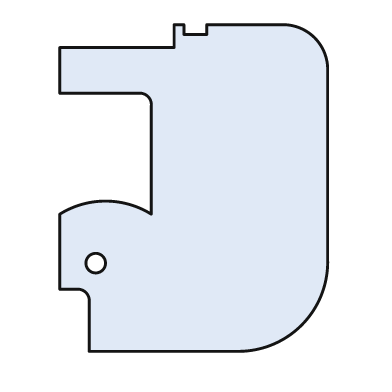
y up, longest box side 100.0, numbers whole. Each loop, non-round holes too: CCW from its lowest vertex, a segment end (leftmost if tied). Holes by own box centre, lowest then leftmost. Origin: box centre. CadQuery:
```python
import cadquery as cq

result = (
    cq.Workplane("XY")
    .moveTo(-32.0, -50.0)
    .lineTo(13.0, -50.0)
    .threePointArc((33.0, -42.0), (41.0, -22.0))
    .lineTo(41.0, 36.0)
    .threePointArc((37.0, 46.0), (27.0, 50.0))
    .lineTo(4.0, 50.0)
    .lineTo(4.0, 47.0)
    .lineTo(-3.0, 47.0)
    .lineTo(-3.0, 50.0)
    .lineTo(-6.0, 50.0)
    .lineTo(-6.0, 43.0)
    .lineTo(-41.0, 43.0)
    .lineTo(-41.0, 29.0)
    .lineTo(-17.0, 29.0)
    .threePointArc((-14.0, 28.0), (-13.0, 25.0))
    .lineTo(-13.0, -8.0)
    .threePointArc((-27.0, -4.0), (-41.0, -8.0))
    .lineTo(-41.0, -31.0)
    .lineTo(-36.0, -31.0)
    .threePointArc((-33.0, -32.0), (-32.0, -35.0))
    .close()
    .moveTo(-30.0, -23.0)
    .circle(3.0)
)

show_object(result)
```